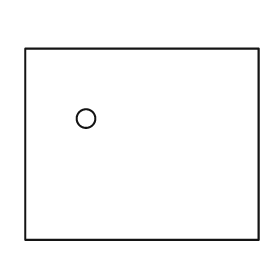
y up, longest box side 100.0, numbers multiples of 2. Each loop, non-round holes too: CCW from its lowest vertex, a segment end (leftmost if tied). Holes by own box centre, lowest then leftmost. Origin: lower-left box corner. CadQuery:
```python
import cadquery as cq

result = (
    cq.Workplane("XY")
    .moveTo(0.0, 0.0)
    .lineTo(100.0, 0.0)
    .lineTo(100.0, 82.0)
    .lineTo(0.0, 82.0)
    .close()
    .moveTo(26.0, 52.0)
    .circle(4.0)
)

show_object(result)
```